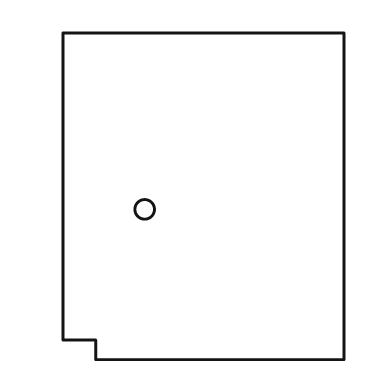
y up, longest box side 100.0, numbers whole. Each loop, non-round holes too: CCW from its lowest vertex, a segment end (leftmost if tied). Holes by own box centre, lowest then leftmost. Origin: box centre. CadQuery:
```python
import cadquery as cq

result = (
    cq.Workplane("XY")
    .moveTo(-33.0, -50.0)
    .lineTo(43.0, -50.0)
    .lineTo(43.0, 50.0)
    .lineTo(-43.0, 50.0)
    .lineTo(-43.0, -44.0)
    .lineTo(-33.0, -44.0)
    .close()
    .moveTo(-18.0, -4.0)
    .circle(3.0)
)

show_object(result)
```